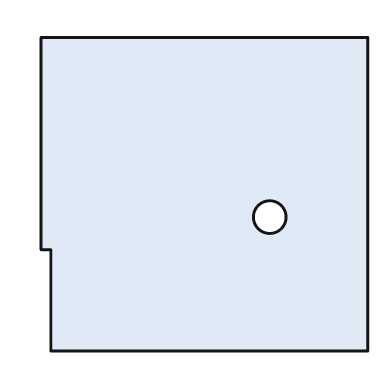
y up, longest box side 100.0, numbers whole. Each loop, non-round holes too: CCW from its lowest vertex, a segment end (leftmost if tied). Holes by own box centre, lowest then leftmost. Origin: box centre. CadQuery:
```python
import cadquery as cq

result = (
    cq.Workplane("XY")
    .moveTo(-47.0, -48.0)
    .lineTo(50.0, -48.0)
    .lineTo(50.0, 48.0)
    .lineTo(-50.0, 48.0)
    .lineTo(-50.0, -17.0)
    .lineTo(-47.0, -17.0)
    .close()
    .moveTo(20.0, -7.0)
    .circle(5.0)
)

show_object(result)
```